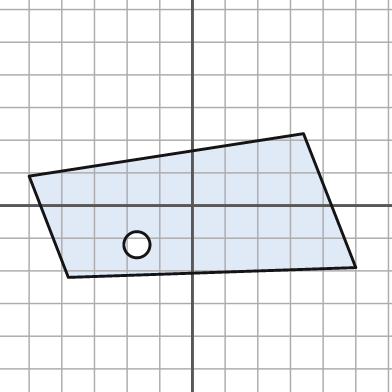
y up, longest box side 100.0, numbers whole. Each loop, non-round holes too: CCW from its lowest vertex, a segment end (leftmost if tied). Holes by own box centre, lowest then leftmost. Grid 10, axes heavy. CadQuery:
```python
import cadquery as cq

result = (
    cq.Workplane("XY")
    .moveTo(-38.0, -22.0)
    .lineTo(50.0, -19.0)
    .lineTo(34.0, 22.0)
    .lineTo(-50.0, 9.0)
    .close()
    .moveTo(-17.0, -12.0)
    .circle(4.0)
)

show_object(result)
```